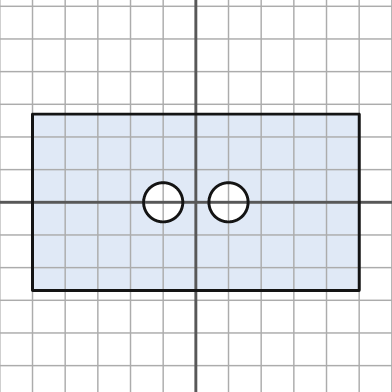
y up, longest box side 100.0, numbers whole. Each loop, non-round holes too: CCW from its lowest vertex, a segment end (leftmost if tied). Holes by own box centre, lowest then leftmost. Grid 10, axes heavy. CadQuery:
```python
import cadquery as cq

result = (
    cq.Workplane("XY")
    .moveTo(-50.0, -27.0)
    .lineTo(50.0, -27.0)
    .lineTo(50.0, 27.0)
    .lineTo(-50.0, 27.0)
    .close()
    .moveTo(-10.0, 0.0)
    .circle(6.0)
    .moveTo(10.0, 0.0)
    .circle(6.0)
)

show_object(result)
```